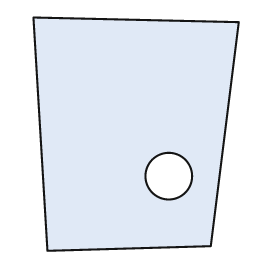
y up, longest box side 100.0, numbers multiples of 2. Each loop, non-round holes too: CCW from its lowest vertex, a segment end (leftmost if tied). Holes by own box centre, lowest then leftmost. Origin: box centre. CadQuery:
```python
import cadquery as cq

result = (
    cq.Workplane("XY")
    .moveTo(-38.0, -50.0)
    .lineTo(32.0, -48.0)
    .lineTo(44.0, 48.0)
    .lineTo(-44.0, 50.0)
    .close()
    .moveTo(14.0, -18.0)
    .circle(10.0)
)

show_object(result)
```